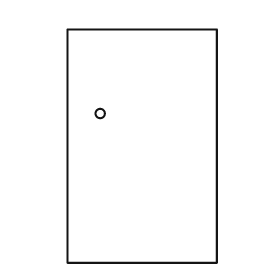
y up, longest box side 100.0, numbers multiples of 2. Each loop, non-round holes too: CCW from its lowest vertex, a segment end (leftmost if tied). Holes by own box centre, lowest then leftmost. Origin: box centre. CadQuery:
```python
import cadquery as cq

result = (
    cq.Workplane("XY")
    .moveTo(-32.0, -50.0)
    .lineTo(32.0, -50.0)
    .lineTo(32.0, 50.0)
    .lineTo(-32.0, 50.0)
    .close()
    .moveTo(-18.0, 14.0)
    .circle(2.0)
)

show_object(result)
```